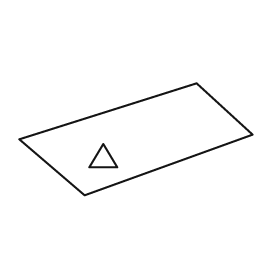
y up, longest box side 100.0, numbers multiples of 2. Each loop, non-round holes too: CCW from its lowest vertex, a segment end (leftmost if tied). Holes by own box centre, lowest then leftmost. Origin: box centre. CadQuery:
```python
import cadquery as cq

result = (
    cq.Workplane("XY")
    .moveTo(-22.0, -24.0)
    .lineTo(50.0, 2.0)
    .lineTo(26.0, 24.0)
    .lineTo(-50.0, 0.0)
    .close()
    .moveTo(-20.0, -12.0)
    .lineTo(-8.0, -12.0)
    .lineTo(-14.0, -2.0)
    .close()
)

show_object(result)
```